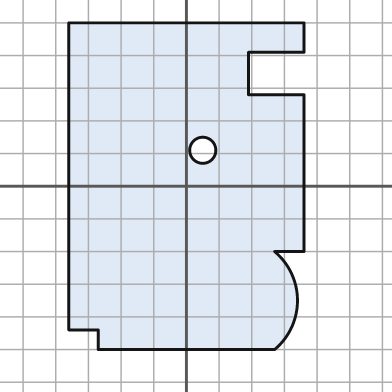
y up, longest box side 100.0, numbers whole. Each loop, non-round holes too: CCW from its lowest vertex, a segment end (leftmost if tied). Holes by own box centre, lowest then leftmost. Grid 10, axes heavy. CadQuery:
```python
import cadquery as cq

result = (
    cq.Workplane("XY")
    .moveTo(-27.0, -50.0)
    .lineTo(27.0, -50.0)
    .threePointArc((34.0, -35.0), (27.0, -20.0))
    .lineTo(36.0, -20.0)
    .lineTo(36.0, 28.0)
    .lineTo(19.0, 28.0)
    .lineTo(19.0, 41.0)
    .lineTo(36.0, 41.0)
    .lineTo(36.0, 50.0)
    .lineTo(-36.0, 50.0)
    .lineTo(-36.0, -44.0)
    .lineTo(-27.0, -44.0)
    .close()
    .moveTo(5.0, 11.0)
    .circle(4.0)
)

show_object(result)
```